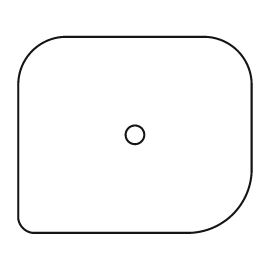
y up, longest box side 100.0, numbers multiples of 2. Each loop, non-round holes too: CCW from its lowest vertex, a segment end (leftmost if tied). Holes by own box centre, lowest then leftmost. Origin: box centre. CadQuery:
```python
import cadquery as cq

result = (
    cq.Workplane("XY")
    .moveTo(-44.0, -42.0)
    .lineTo(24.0, -42.0)
    .threePointArc((42.0, -34.0), (50.0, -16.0))
    .lineTo(50.0, 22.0)
    .threePointArc((44.0, 36.0), (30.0, 42.0))
    .lineTo(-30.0, 42.0)
    .threePointArc((-44.0, 36.0), (-50.0, 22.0))
    .lineTo(-50.0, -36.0)
    .threePointArc((-48.0, -40.0), (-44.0, -42.0))
    .close()
    .moveTo(0.0, 0.0)
    .circle(4.0)
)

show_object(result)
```